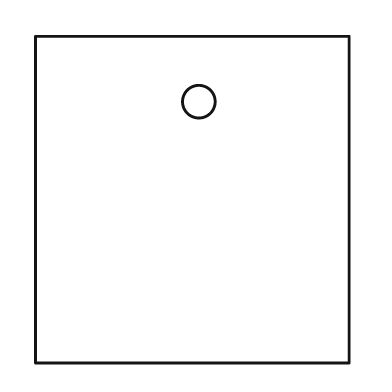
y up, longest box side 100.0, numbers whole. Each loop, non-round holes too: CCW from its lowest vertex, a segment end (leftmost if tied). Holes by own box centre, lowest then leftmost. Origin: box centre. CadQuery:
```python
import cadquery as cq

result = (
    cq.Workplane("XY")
    .moveTo(-48.0, -50.0)
    .lineTo(48.0, -50.0)
    .lineTo(48.0, 50.0)
    .lineTo(-48.0, 50.0)
    .close()
    .moveTo(2.0, 30.0)
    .circle(5.0)
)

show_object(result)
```